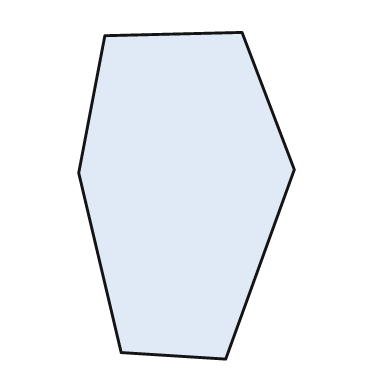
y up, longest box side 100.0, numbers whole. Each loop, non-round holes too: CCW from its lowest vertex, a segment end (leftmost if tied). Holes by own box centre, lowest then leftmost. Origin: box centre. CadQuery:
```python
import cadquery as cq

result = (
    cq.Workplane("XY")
    .moveTo(12.0, -50.0)
    .lineTo(33.0, 8.0)
    .lineTo(17.0, 50.0)
    .lineTo(-25.0, 49.0)
    .lineTo(-33.0, 7.0)
    .lineTo(-20.0, -48.0)
    .close()
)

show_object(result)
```